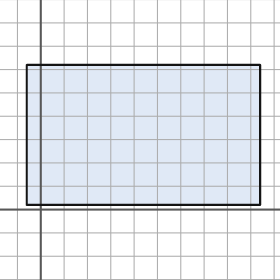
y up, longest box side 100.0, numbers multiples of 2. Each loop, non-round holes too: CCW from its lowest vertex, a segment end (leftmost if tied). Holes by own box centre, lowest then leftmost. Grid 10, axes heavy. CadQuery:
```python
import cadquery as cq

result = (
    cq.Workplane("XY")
    .moveTo(-6.0, 2.0)
    .lineTo(94.0, 2.0)
    .lineTo(94.0, 62.0)
    .lineTo(-6.0, 62.0)
    .close()
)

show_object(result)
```